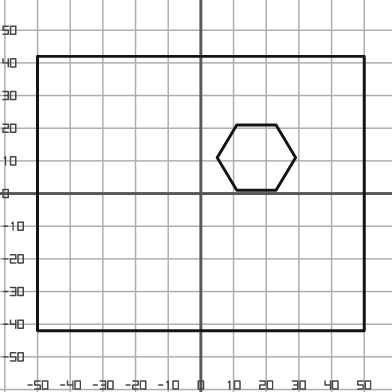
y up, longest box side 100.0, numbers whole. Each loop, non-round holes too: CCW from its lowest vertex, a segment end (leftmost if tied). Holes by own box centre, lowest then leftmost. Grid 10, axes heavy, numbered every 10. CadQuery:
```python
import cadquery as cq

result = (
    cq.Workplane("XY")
    .moveTo(-50.0, -42.0)
    .lineTo(50.0, -42.0)
    .lineTo(50.0, 42.0)
    .lineTo(-50.0, 42.0)
    .close()
    .moveTo(11.0, 1.0)
    .lineTo(23.0, 1.0)
    .lineTo(29.0, 11.0)
    .lineTo(23.0, 21.0)
    .lineTo(11.0, 21.0)
    .lineTo(5.0, 11.0)
    .close()
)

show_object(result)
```